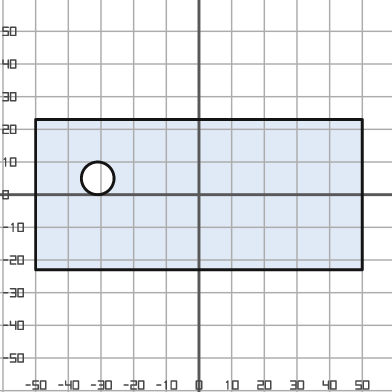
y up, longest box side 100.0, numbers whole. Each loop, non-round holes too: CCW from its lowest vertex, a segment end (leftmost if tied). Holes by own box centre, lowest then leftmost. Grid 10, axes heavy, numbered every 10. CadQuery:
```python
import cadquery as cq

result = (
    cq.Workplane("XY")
    .moveTo(-50.0, -23.0)
    .lineTo(50.0, -23.0)
    .lineTo(50.0, 23.0)
    .lineTo(-50.0, 23.0)
    .close()
    .moveTo(-31.0, 5.0)
    .circle(5.0)
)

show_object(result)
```